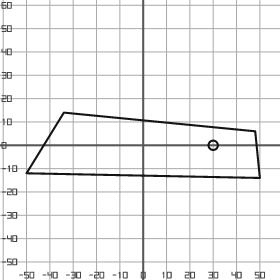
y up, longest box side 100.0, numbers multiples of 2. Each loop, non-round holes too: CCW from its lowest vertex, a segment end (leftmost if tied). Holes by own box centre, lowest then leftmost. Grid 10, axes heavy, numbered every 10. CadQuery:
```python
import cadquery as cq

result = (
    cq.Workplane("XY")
    .moveTo(50.0, -14.0)
    .lineTo(48.0, 6.0)
    .lineTo(-34.0, 14.0)
    .lineTo(-50.0, -12.0)
    .close()
    .moveTo(30.0, 0.0)
    .circle(2.0)
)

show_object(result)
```